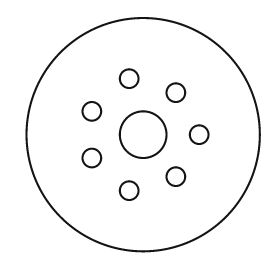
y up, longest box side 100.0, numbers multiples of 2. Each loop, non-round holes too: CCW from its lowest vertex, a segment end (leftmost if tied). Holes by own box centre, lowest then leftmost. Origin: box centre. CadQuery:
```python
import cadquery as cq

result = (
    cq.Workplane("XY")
    .moveTo(0.0, 0.0)
    .circle(50.0)
    .moveTo(-6.0, -24.0)
    .circle(4.0)
    .moveTo(14.0, -18.0)
    .circle(4.0)
    .moveTo(-22.0, -10.0)
    .circle(4.0)
    .moveTo(0.0, 0.0)
    .circle(10.0)
    .moveTo(24.0, 0.0)
    .circle(4.0)
    .moveTo(-22.0, 10.0)
    .circle(4.0)
    .moveTo(14.0, 18.0)
    .circle(4.0)
    .moveTo(-6.0, 24.0)
    .circle(4.0)
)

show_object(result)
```